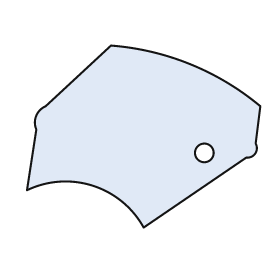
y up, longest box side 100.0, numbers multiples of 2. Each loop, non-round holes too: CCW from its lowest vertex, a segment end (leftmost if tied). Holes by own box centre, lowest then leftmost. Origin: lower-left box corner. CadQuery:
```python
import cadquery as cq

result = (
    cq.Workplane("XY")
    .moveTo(50.0, 0.0)
    .lineTo(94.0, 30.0)
    .threePointArc((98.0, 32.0), (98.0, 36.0))
    .lineTo(100.0, 52.0)
    .threePointArc((70.0, 70.0), (36.0, 78.0))
    .lineTo(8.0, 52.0)
    .threePointArc((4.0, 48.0), (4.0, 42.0))
    .lineTo(0.0, 16.0)
    .threePointArc((28.0, 18.0), (50.0, 0.0))
    .close()
    .moveTo(76.0, 32.0)
    .circle(4.0)
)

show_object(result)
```